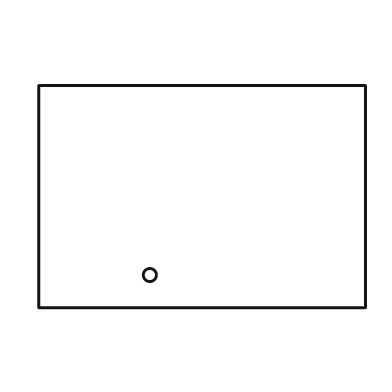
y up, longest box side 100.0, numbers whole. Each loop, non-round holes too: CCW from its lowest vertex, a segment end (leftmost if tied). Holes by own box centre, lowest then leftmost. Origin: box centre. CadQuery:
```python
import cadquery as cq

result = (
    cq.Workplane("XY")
    .moveTo(-50.0, -34.0)
    .lineTo(50.0, -34.0)
    .lineTo(50.0, 34.0)
    .lineTo(-50.0, 34.0)
    .close()
    .moveTo(-16.0, -24.0)
    .circle(2.0)
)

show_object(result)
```